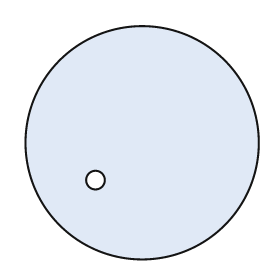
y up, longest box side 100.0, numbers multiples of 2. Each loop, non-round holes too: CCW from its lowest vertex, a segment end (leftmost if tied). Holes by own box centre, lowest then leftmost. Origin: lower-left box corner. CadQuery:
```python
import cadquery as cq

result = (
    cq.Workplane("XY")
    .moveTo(50.0, 50.0)
    .circle(50.0)
    .moveTo(30.0, 34.0)
    .circle(4.0)
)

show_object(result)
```